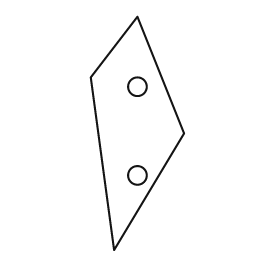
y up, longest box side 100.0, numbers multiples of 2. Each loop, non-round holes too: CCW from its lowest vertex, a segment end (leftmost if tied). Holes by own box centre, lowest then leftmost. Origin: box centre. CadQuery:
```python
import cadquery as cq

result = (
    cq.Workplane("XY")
    .moveTo(-10.0, -50.0)
    .lineTo(20.0, 0.0)
    .lineTo(0.0, 50.0)
    .lineTo(-20.0, 24.0)
    .close()
    .moveTo(0.0, -18.0)
    .circle(4.0)
    .moveTo(0.0, 20.0)
    .circle(4.0)
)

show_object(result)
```